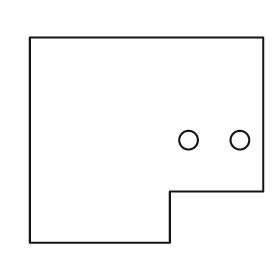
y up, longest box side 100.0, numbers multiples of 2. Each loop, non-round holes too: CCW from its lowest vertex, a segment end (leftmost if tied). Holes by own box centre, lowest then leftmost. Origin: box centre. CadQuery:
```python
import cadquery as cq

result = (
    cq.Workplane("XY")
    .moveTo(-50.0, -44.0)
    .lineTo(10.0, -44.0)
    .lineTo(10.0, -22.0)
    .lineTo(50.0, -22.0)
    .lineTo(50.0, 44.0)
    .lineTo(-50.0, 44.0)
    .close()
    .moveTo(18.0, 0.0)
    .circle(4.0)
    .moveTo(40.0, 0.0)
    .circle(4.0)
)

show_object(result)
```